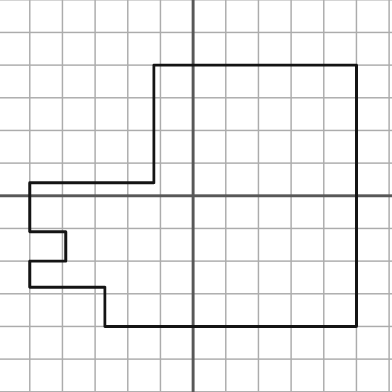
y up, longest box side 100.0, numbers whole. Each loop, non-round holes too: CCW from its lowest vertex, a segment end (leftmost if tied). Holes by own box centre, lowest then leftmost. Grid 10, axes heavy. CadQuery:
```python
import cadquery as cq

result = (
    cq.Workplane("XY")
    .moveTo(-27.0, -40.0)
    .lineTo(50.0, -40.0)
    .lineTo(50.0, 40.0)
    .lineTo(-12.0, 40.0)
    .lineTo(-12.0, 4.0)
    .lineTo(-50.0, 4.0)
    .lineTo(-50.0, -11.0)
    .lineTo(-39.0, -11.0)
    .lineTo(-39.0, -20.0)
    .lineTo(-50.0, -20.0)
    .lineTo(-50.0, -28.0)
    .lineTo(-27.0, -28.0)
    .close()
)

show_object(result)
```